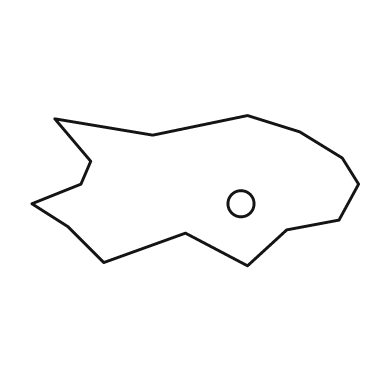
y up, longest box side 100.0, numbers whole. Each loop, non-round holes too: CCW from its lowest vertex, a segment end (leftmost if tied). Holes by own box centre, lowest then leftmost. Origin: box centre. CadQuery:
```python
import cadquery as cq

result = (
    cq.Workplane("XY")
    .moveTo(16.0, -23.0)
    .lineTo(28.0, -12.0)
    .lineTo(44.0, -9.0)
    .lineTo(50.0, 2.0)
    .lineTo(45.0, 10.0)
    .lineTo(32.0, 18.0)
    .lineTo(16.0, 23.0)
    .lineTo(-13.0, 17.0)
    .lineTo(-43.0, 22.0)
    .lineTo(-32.0, 9.0)
    .lineTo(-35.0, 2.0)
    .lineTo(-50.0, -4.0)
    .lineTo(-39.0, -11.0)
    .lineTo(-28.0, -22.0)
    .lineTo(-3.0, -13.0)
    .close()
    .moveTo(14.0, -4.0)
    .circle(4.0)
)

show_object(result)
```